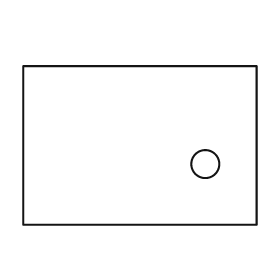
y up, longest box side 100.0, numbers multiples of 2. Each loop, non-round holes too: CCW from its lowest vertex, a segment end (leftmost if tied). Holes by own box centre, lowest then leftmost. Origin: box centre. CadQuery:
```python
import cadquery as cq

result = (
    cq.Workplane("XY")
    .moveTo(-50.0, -34.0)
    .lineTo(50.0, -34.0)
    .lineTo(50.0, 34.0)
    .lineTo(-50.0, 34.0)
    .close()
    .moveTo(28.0, -8.0)
    .circle(6.0)
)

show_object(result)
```